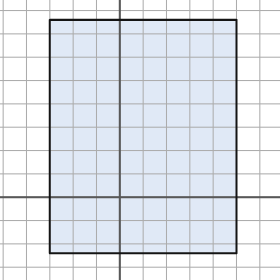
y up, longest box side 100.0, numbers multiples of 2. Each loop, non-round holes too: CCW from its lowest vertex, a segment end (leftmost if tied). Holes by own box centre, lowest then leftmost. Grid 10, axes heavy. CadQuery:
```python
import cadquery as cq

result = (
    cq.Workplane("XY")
    .moveTo(-30.0, -24.0)
    .lineTo(50.0, -24.0)
    .lineTo(50.0, 76.0)
    .lineTo(-30.0, 76.0)
    .close()
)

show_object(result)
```